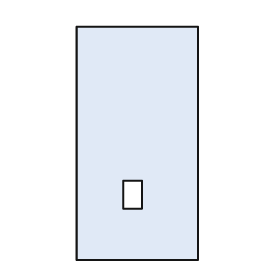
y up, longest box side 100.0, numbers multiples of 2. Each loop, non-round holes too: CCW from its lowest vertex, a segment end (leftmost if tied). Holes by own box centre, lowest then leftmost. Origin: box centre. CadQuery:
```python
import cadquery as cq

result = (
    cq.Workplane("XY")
    .moveTo(-26.0, -50.0)
    .lineTo(26.0, -50.0)
    .lineTo(26.0, 50.0)
    .lineTo(-26.0, 50.0)
    .close()
    .moveTo(-6.0, -28.0)
    .lineTo(2.0, -28.0)
    .lineTo(2.0, -16.0)
    .lineTo(-6.0, -16.0)
    .close()
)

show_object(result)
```